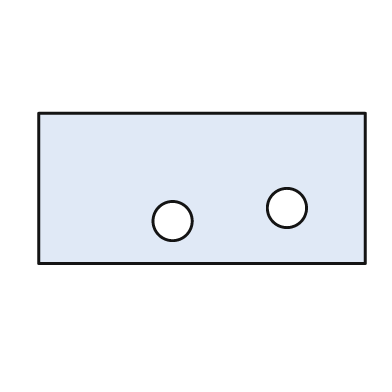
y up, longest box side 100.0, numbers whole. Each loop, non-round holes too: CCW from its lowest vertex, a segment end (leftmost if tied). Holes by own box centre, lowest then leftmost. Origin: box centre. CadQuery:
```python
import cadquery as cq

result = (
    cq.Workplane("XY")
    .moveTo(-50.0, -23.0)
    .lineTo(50.0, -23.0)
    .lineTo(50.0, 23.0)
    .lineTo(-50.0, 23.0)
    .close()
    .moveTo(-9.0, -10.0)
    .circle(6.0)
    .moveTo(26.0, -6.0)
    .circle(6.0)
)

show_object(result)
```